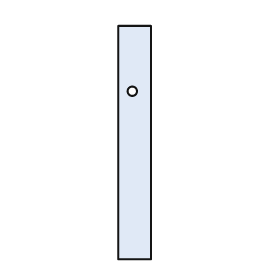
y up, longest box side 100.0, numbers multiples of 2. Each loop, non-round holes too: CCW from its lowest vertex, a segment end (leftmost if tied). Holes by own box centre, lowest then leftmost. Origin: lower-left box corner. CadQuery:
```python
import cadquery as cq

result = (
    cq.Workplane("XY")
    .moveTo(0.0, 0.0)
    .lineTo(14.0, 0.0)
    .lineTo(14.0, 100.0)
    .lineTo(0.0, 100.0)
    .close()
    .moveTo(6.0, 72.0)
    .circle(2.0)
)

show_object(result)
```